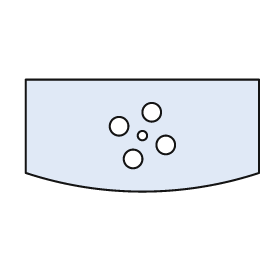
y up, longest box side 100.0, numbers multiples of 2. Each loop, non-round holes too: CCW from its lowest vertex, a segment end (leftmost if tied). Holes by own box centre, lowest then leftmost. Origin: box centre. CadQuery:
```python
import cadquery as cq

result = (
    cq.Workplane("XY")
    .moveTo(-50.0, -16.0)
    .threePointArc((0.0, -24.0), (50.0, -16.0))
    .lineTo(50.0, 24.0)
    .lineTo(-50.0, 24.0)
    .close()
    .moveTo(-4.0, -10.0)
    .circle(4.0)
    .moveTo(10.0, -4.0)
    .circle(4.0)
    .moveTo(0.0, 0.0)
    .circle(2.0)
    .moveTo(-10.0, 4.0)
    .circle(4.0)
    .moveTo(4.0, 10.0)
    .circle(4.0)
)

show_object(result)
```